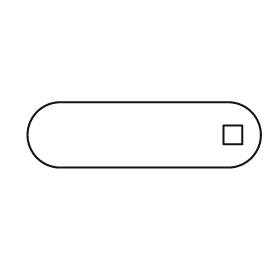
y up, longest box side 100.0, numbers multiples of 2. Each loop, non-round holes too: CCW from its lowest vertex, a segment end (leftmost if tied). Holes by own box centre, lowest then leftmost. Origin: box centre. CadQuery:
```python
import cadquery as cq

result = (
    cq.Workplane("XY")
    .moveTo(-36.0, -14.0)
    .lineTo(36.0, -14.0)
    .threePointArc((50.0, 0.0), (36.0, 14.0))
    .lineTo(-36.0, 14.0)
    .threePointArc((-50.0, 0.0), (-36.0, -14.0))
    .close()
    .moveTo(34.0, -4.0)
    .lineTo(42.0, -4.0)
    .lineTo(42.0, 4.0)
    .lineTo(34.0, 4.0)
    .close()
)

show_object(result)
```